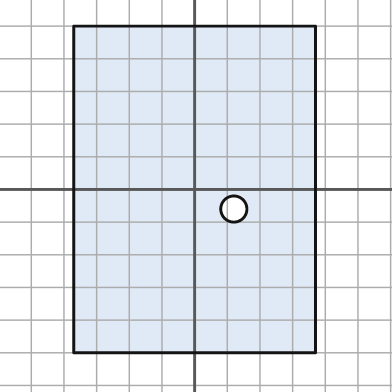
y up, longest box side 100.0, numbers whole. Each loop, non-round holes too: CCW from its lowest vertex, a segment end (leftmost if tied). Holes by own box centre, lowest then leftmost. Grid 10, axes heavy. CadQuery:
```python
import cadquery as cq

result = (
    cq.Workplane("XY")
    .moveTo(-37.0, -50.0)
    .lineTo(37.0, -50.0)
    .lineTo(37.0, 50.0)
    .lineTo(-37.0, 50.0)
    .close()
    .moveTo(12.0, -6.0)
    .circle(4.0)
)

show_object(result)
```